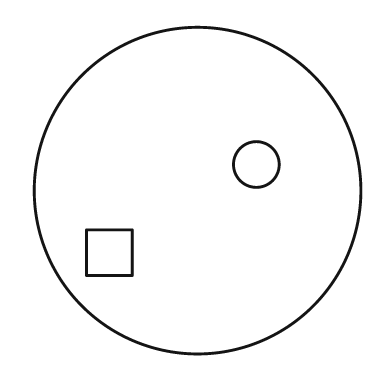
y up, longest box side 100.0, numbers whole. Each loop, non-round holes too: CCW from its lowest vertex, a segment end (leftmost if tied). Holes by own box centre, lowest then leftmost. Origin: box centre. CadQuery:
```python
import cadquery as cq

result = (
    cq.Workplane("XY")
    .moveTo(0.0, 0.0)
    .circle(50.0)
    .moveTo(-34.0, -26.0)
    .lineTo(-20.0, -26.0)
    .lineTo(-20.0, -12.0)
    .lineTo(-34.0, -12.0)
    .close()
    .moveTo(18.0, 8.0)
    .circle(7.0)
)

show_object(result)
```